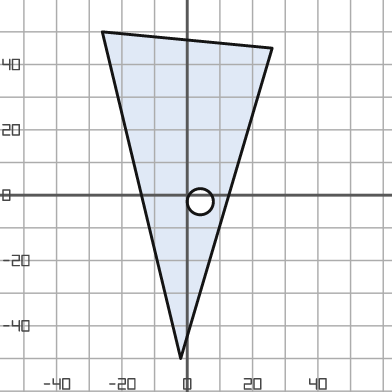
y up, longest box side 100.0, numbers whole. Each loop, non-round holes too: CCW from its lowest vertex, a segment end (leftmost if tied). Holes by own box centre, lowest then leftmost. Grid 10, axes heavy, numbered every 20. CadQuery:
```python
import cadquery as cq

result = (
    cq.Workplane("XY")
    .moveTo(-2.0, -50.0)
    .lineTo(26.0, 45.0)
    .lineTo(-26.0, 50.0)
    .close()
    .moveTo(4.0, -2.0)
    .circle(4.0)
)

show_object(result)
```